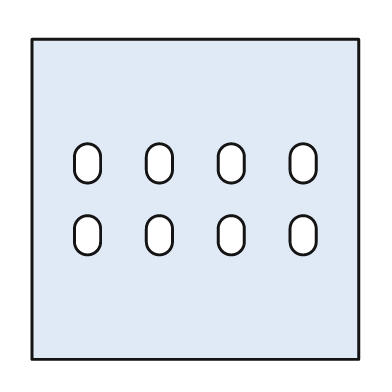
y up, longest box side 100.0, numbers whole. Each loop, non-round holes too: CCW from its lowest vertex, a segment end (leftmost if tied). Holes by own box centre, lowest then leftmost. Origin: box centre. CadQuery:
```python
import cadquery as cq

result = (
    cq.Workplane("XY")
    .moveTo(-50.0, -49.0)
    .lineTo(50.0, -49.0)
    .lineTo(50.0, 49.0)
    .lineTo(-50.0, 49.0)
    .close()
    .moveTo(-37.0, -13.0)
    .threePointArc((-33.0, -17.0), (-29.0, -13.0))
    .lineTo(-29.0, -9.0)
    .threePointArc((-33.0, -5.0), (-37.0, -9.0))
    .close()
    .moveTo(-15.0, -13.0)
    .threePointArc((-11.0, -17.0), (-7.0, -13.0))
    .lineTo(-7.0, -9.0)
    .threePointArc((-11.0, -5.0), (-15.0, -9.0))
    .close()
    .moveTo(7.0, -13.0)
    .threePointArc((11.0, -17.0), (15.0, -13.0))
    .lineTo(15.0, -9.0)
    .threePointArc((11.0, -5.0), (7.0, -9.0))
    .close()
    .moveTo(29.0, -13.0)
    .threePointArc((33.0, -17.0), (37.0, -13.0))
    .lineTo(37.0, -9.0)
    .threePointArc((33.0, -5.0), (29.0, -9.0))
    .close()
    .moveTo(-37.0, 9.0)
    .threePointArc((-33.0, 5.0), (-29.0, 9.0))
    .lineTo(-29.0, 13.0)
    .threePointArc((-33.0, 17.0), (-37.0, 13.0))
    .close()
    .moveTo(-15.0, 9.0)
    .threePointArc((-11.0, 5.0), (-7.0, 9.0))
    .lineTo(-7.0, 13.0)
    .threePointArc((-11.0, 17.0), (-15.0, 13.0))
    .close()
    .moveTo(7.0, 9.0)
    .threePointArc((11.0, 5.0), (15.0, 9.0))
    .lineTo(15.0, 13.0)
    .threePointArc((11.0, 17.0), (7.0, 13.0))
    .close()
    .moveTo(29.0, 9.0)
    .threePointArc((33.0, 5.0), (37.0, 9.0))
    .lineTo(37.0, 13.0)
    .threePointArc((33.0, 17.0), (29.0, 13.0))
    .close()
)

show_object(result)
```